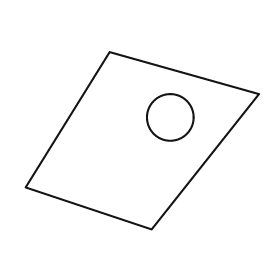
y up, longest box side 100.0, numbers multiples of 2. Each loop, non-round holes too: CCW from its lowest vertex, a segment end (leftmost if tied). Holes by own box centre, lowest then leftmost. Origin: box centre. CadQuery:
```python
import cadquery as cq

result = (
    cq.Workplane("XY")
    .moveTo(4.0, -38.0)
    .lineTo(50.0, 20.0)
    .lineTo(-14.0, 38.0)
    .lineTo(-50.0, -20.0)
    .close()
    .moveTo(12.0, 10.0)
    .circle(10.0)
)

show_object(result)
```